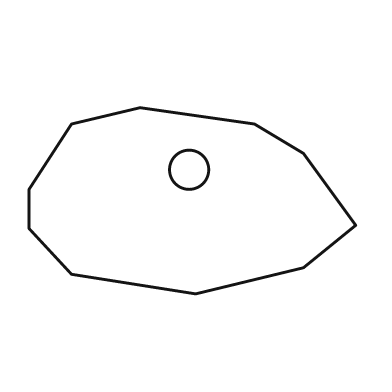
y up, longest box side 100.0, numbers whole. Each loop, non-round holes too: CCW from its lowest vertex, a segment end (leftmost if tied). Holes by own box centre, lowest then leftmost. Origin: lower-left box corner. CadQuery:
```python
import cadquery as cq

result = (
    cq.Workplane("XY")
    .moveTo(51.0, 0.0)
    .lineTo(84.0, 8.0)
    .lineTo(100.0, 21.0)
    .lineTo(84.0, 43.0)
    .lineTo(69.0, 52.0)
    .lineTo(34.0, 57.0)
    .lineTo(13.0, 52.0)
    .lineTo(0.0, 32.0)
    .lineTo(0.0, 20.0)
    .lineTo(13.0, 6.0)
    .close()
    .moveTo(49.0, 38.0)
    .circle(6.0)
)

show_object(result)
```